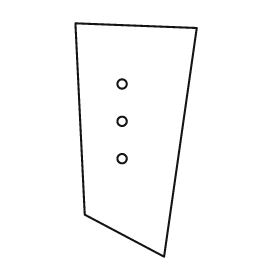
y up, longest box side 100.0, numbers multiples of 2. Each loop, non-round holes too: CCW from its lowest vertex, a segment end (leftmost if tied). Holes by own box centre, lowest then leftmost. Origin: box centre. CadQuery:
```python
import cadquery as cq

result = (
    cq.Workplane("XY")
    .moveTo(12.0, -50.0)
    .lineTo(26.0, 48.0)
    .lineTo(-26.0, 50.0)
    .lineTo(-22.0, -32.0)
    .close()
    .moveTo(-6.0, -8.0)
    .circle(2.0)
    .moveTo(-6.0, 8.0)
    .circle(2.0)
    .moveTo(-6.0, 24.0)
    .circle(2.0)
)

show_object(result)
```